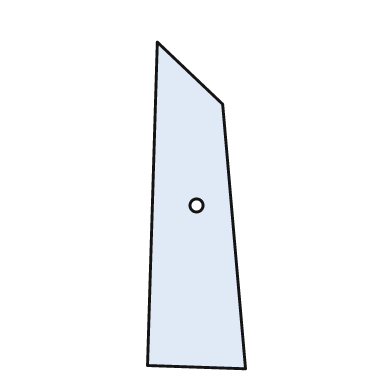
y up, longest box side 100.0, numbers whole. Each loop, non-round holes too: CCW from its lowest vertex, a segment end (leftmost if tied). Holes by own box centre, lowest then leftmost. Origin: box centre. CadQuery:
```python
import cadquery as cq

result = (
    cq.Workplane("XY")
    .moveTo(15.0, -50.0)
    .lineTo(8.0, 31.0)
    .lineTo(-12.0, 50.0)
    .lineTo(-15.0, -49.0)
    .close()
    .moveTo(0.0, 0.0)
    .circle(2.0)
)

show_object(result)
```